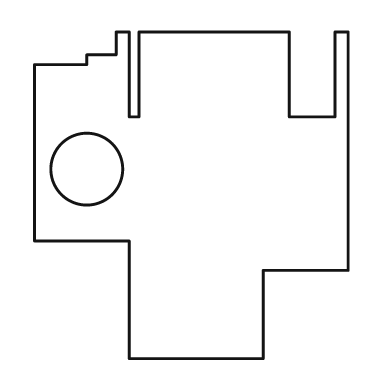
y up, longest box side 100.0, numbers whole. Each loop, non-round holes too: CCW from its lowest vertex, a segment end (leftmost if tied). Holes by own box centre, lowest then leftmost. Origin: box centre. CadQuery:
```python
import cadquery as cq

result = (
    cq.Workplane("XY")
    .moveTo(-19.0, -50.0)
    .lineTo(22.0, -50.0)
    .lineTo(22.0, -23.0)
    .lineTo(48.0, -23.0)
    .lineTo(48.0, 50.0)
    .lineTo(44.0, 50.0)
    .lineTo(44.0, 24.0)
    .lineTo(30.0, 24.0)
    .lineTo(30.0, 50.0)
    .lineTo(-16.0, 50.0)
    .lineTo(-16.0, 24.0)
    .lineTo(-19.0, 24.0)
    .lineTo(-19.0, 50.0)
    .lineTo(-23.0, 50.0)
    .lineTo(-23.0, 43.0)
    .lineTo(-32.0, 43.0)
    .lineTo(-32.0, 40.0)
    .lineTo(-48.0, 40.0)
    .lineTo(-48.0, -14.0)
    .lineTo(-19.0, -14.0)
    .close()
    .moveTo(-32.0, 8.0)
    .circle(11.0)
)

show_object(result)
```